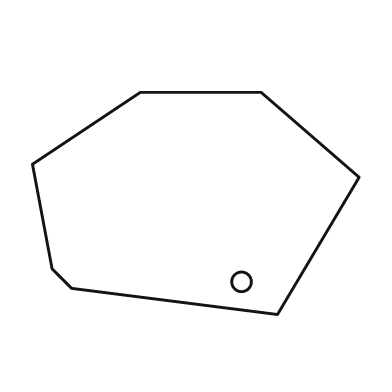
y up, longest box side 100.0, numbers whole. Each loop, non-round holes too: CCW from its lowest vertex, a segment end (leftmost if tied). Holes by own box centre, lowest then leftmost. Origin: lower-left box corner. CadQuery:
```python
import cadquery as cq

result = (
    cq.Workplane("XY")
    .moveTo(75.0, 0.0)
    .lineTo(100.0, 42.0)
    .lineTo(70.0, 68.0)
    .lineTo(33.0, 68.0)
    .lineTo(0.0, 46.0)
    .lineTo(6.0, 14.0)
    .lineTo(12.0, 8.0)
    .close()
    .moveTo(64.0, 10.0)
    .circle(3.0)
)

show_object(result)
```